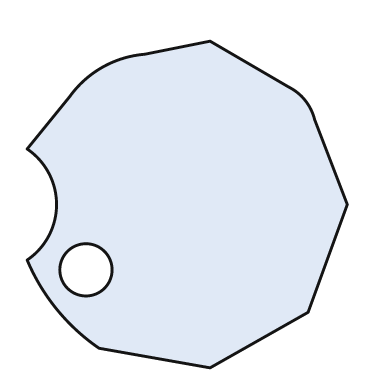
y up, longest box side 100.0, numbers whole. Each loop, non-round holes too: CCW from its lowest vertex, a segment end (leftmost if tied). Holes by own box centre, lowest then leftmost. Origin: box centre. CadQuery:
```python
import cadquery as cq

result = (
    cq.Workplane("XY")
    .moveTo(7.0, -50.0)
    .lineTo(37.0, -33.0)
    .lineTo(49.0, 0.0)
    .lineTo(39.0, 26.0)
    .threePointArc((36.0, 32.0), (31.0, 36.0))
    .lineTo(7.0, 50.0)
    .lineTo(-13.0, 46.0)
    .threePointArc((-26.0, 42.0), (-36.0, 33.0))
    .lineTo(-49.0, 17.0)
    .threePointArc((-40.0, 0.0), (-49.0, -17.0))
    .threePointArc((-40.0, -32.0), (-27.0, -44.0))
    .close()
    .moveTo(-31.0, -20.0)
    .circle(8.0)
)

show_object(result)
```